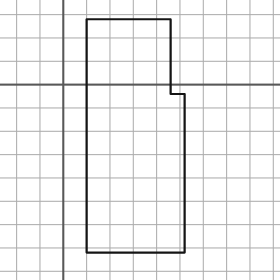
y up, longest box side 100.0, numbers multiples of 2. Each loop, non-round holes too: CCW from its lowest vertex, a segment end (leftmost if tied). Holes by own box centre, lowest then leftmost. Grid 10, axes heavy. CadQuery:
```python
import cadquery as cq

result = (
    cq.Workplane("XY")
    .moveTo(10.0, -72.0)
    .lineTo(52.0, -72.0)
    .lineTo(52.0, -4.0)
    .lineTo(46.0, -4.0)
    .lineTo(46.0, 28.0)
    .lineTo(10.0, 28.0)
    .close()
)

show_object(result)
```